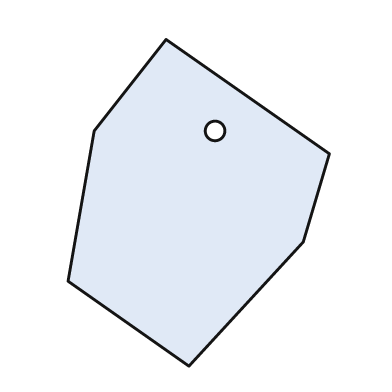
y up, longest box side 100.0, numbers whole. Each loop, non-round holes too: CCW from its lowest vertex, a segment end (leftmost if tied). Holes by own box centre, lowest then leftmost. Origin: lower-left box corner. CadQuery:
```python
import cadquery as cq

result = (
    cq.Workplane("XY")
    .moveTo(37.0, 0.0)
    .lineTo(72.0, 38.0)
    .lineTo(80.0, 65.0)
    .lineTo(30.0, 100.0)
    .lineTo(8.0, 72.0)
    .lineTo(0.0, 26.0)
    .close()
    .moveTo(45.0, 72.0)
    .circle(3.0)
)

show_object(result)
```